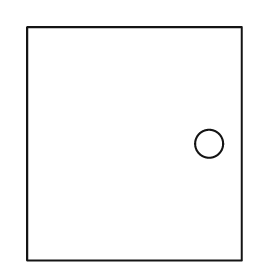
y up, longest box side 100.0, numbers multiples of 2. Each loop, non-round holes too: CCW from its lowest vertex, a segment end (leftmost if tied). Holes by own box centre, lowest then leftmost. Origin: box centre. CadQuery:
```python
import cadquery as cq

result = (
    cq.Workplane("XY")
    .moveTo(-46.0, -50.0)
    .lineTo(46.0, -50.0)
    .lineTo(46.0, 50.0)
    .lineTo(-46.0, 50.0)
    .close()
    .moveTo(32.0, 0.0)
    .circle(6.0)
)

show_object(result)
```